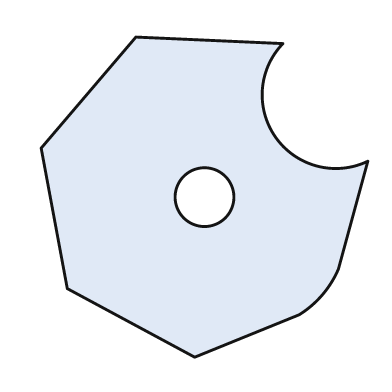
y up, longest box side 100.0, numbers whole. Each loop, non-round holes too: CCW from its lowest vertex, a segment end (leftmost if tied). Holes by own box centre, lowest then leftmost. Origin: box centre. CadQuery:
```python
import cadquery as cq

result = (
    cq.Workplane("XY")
    .moveTo(-3.0, -49.0)
    .lineTo(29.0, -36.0)
    .threePointArc((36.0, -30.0), (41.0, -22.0))
    .lineTo(50.0, 11.0)
    .threePointArc((22.0, 18.0), (24.0, 47.0))
    .lineTo(-21.0, 49.0)
    .lineTo(-50.0, 15.0)
    .lineTo(-42.0, -28.0)
    .close()
    .moveTo(0.0, 0.0)
    .circle(9.0)
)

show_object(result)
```